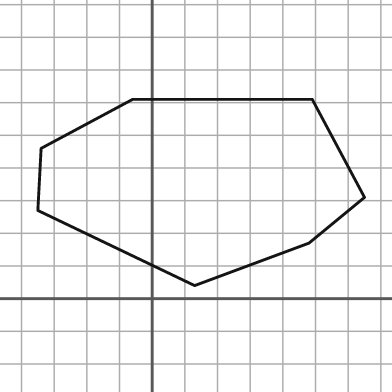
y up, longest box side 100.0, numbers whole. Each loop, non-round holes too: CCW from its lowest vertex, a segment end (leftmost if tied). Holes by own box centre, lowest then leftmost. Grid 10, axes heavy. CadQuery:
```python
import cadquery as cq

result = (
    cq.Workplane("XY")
    .moveTo(13.0, 4.0)
    .lineTo(48.0, 17.0)
    .lineTo(65.0, 31.0)
    .lineTo(49.0, 61.0)
    .lineTo(-6.0, 61.0)
    .lineTo(-34.0, 46.0)
    .lineTo(-35.0, 27.0)
    .close()
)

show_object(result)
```